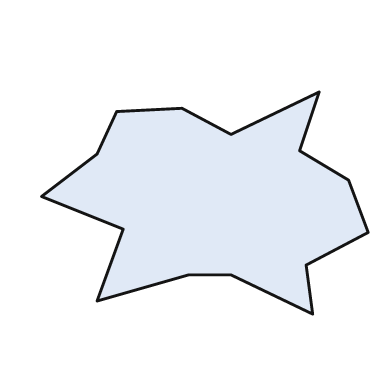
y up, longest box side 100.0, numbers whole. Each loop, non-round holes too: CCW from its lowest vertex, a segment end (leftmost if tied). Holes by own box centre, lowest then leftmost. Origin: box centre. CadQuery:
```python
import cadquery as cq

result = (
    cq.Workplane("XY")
    .moveTo(33.0, -34.0)
    .lineTo(31.0, -19.0)
    .lineTo(50.0, -9.0)
    .lineTo(44.0, 7.0)
    .lineTo(29.0, 16.0)
    .lineTo(35.0, 34.0)
    .lineTo(8.0, 21.0)
    .lineTo(-7.0, 29.0)
    .lineTo(-27.0, 28.0)
    .lineTo(-33.0, 15.0)
    .lineTo(-50.0, 2.0)
    .lineTo(-25.0, -8.0)
    .lineTo(-33.0, -30.0)
    .lineTo(-5.0, -22.0)
    .lineTo(8.0, -22.0)
    .close()
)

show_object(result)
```